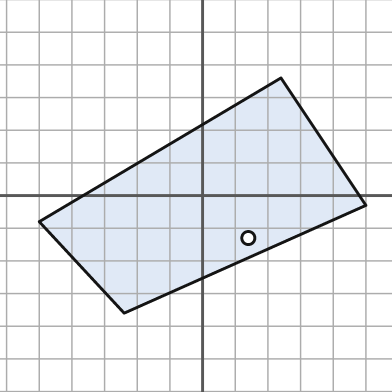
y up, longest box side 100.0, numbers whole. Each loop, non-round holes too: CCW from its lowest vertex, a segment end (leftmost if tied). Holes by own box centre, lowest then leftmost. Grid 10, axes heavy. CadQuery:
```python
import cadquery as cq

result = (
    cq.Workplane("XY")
    .moveTo(-24.0, -36.0)
    .lineTo(50.0, -3.0)
    .lineTo(24.0, 36.0)
    .lineTo(-50.0, -8.0)
    .close()
    .moveTo(14.0, -13.0)
    .circle(2.0)
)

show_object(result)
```